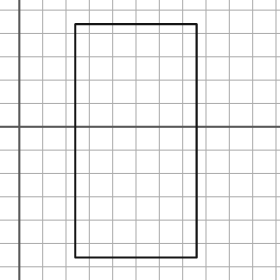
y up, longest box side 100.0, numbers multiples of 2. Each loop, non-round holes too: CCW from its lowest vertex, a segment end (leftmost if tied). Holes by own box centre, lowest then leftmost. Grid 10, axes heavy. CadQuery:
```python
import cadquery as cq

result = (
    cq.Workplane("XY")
    .moveTo(24.0, -56.0)
    .lineTo(76.0, -56.0)
    .lineTo(76.0, 44.0)
    .lineTo(24.0, 44.0)
    .close()
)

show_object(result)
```